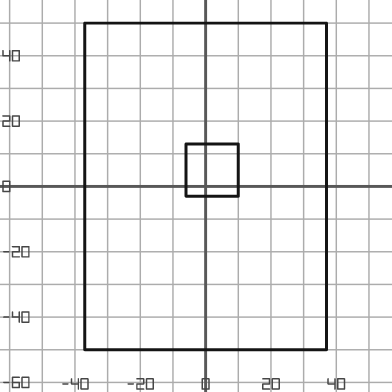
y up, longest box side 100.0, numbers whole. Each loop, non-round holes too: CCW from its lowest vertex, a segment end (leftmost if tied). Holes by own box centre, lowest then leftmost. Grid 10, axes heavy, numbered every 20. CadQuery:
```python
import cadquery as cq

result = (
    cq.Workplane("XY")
    .moveTo(-37.0, -50.0)
    .lineTo(37.0, -50.0)
    .lineTo(37.0, 50.0)
    .lineTo(-37.0, 50.0)
    .close()
    .moveTo(-6.0, -3.0)
    .lineTo(10.0, -3.0)
    .lineTo(10.0, 13.0)
    .lineTo(-6.0, 13.0)
    .close()
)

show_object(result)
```